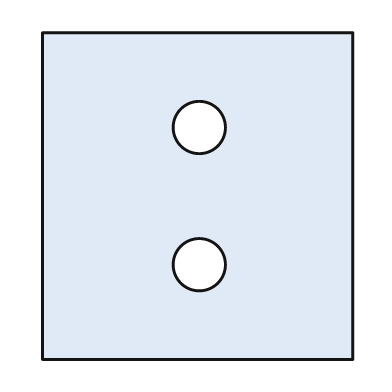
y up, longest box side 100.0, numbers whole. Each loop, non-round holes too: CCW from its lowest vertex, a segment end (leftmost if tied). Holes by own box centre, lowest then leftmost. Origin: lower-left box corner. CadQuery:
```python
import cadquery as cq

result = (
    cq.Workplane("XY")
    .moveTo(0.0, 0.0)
    .lineTo(95.0, 0.0)
    .lineTo(95.0, 100.0)
    .lineTo(0.0, 100.0)
    .close()
    .moveTo(48.0, 29.0)
    .circle(8.0)
    .moveTo(48.0, 71.0)
    .circle(8.0)
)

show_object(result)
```